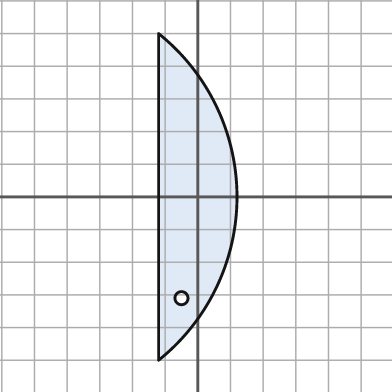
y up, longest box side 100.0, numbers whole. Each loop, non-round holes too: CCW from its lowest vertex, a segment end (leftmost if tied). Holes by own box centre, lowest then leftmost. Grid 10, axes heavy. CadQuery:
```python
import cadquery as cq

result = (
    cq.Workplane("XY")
    .moveTo(-12.0, -50.0)
    .threePointArc((12.0, 0.0), (-12.0, 50.0))
    .close()
    .moveTo(-5.0, -31.0)
    .circle(2.0)
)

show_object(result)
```